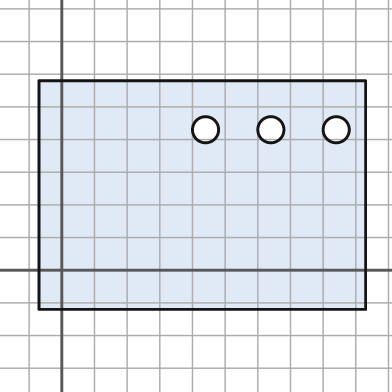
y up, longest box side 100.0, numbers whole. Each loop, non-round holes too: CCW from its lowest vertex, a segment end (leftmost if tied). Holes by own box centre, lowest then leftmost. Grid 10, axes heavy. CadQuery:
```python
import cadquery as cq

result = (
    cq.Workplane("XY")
    .moveTo(-7.0, -12.0)
    .lineTo(93.0, -12.0)
    .lineTo(93.0, 58.0)
    .lineTo(-7.0, 58.0)
    .close()
    .moveTo(44.0, 43.0)
    .circle(4.0)
    .moveTo(64.0, 43.0)
    .circle(4.0)
    .moveTo(84.0, 43.0)
    .circle(4.0)
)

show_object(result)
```